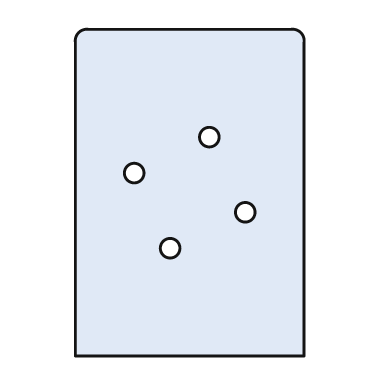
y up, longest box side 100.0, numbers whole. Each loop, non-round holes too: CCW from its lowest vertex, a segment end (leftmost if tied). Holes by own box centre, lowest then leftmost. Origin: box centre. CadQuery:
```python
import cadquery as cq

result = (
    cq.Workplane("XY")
    .moveTo(-35.0, -50.0)
    .lineTo(35.0, -50.0)
    .lineTo(35.0, 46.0)
    .threePointArc((34.0, 49.0), (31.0, 50.0))
    .lineTo(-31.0, 50.0)
    .threePointArc((-34.0, 49.0), (-35.0, 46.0))
    .close()
    .moveTo(-6.0, -17.0)
    .circle(3.0)
    .moveTo(17.0, -6.0)
    .circle(3.0)
    .moveTo(-17.0, 6.0)
    .circle(3.0)
    .moveTo(6.0, 17.0)
    .circle(3.0)
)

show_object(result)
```